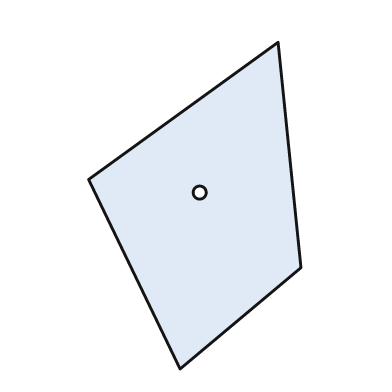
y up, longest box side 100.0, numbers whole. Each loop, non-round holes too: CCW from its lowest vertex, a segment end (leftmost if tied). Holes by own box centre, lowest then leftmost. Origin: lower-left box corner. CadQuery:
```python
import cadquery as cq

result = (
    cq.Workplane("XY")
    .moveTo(28.0, 0.0)
    .lineTo(65.0, 31.0)
    .lineTo(58.0, 100.0)
    .lineTo(0.0, 58.0)
    .close()
    .moveTo(34.0, 54.0)
    .circle(2.0)
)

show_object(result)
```